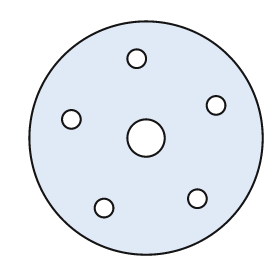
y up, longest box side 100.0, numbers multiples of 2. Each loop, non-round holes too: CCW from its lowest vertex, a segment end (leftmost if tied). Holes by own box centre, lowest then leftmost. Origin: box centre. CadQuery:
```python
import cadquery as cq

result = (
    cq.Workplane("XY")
    .moveTo(0.0, 0.0)
    .circle(50.0)
    .moveTo(-18.0, -30.0)
    .circle(4.0)
    .moveTo(22.0, -26.0)
    .circle(4.0)
    .moveTo(0.0, 0.0)
    .circle(8.0)
    .moveTo(-32.0, 8.0)
    .circle(4.0)
    .moveTo(30.0, 14.0)
    .circle(4.0)
    .moveTo(-4.0, 34.0)
    .circle(4.0)
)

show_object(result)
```